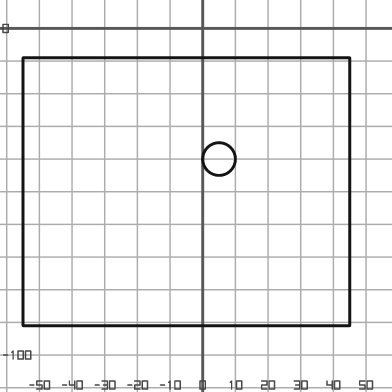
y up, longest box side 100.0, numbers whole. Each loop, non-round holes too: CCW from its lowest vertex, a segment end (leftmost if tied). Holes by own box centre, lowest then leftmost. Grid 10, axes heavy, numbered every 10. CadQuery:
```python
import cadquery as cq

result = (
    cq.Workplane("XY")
    .moveTo(-55.0, -91.0)
    .lineTo(45.0, -91.0)
    .lineTo(45.0, -9.0)
    .lineTo(-55.0, -9.0)
    .close()
    .moveTo(5.0, -40.0)
    .circle(5.0)
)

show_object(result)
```